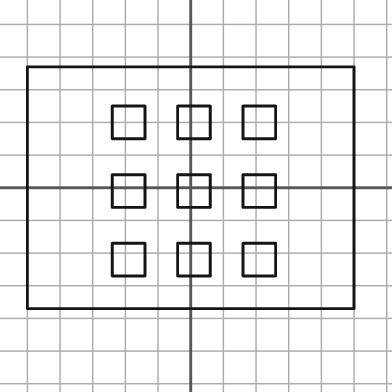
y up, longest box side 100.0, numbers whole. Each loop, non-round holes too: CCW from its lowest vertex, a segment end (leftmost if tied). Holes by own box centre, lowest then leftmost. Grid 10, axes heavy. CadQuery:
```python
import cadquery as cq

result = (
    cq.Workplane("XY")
    .moveTo(-50.0, -37.0)
    .lineTo(50.0, -37.0)
    .lineTo(50.0, 37.0)
    .lineTo(-50.0, 37.0)
    .close()
    .moveTo(-24.0, -27.0)
    .lineTo(-14.0, -27.0)
    .lineTo(-14.0, -17.0)
    .lineTo(-24.0, -17.0)
    .close()
    .moveTo(-4.0, -27.0)
    .lineTo(6.0, -27.0)
    .lineTo(6.0, -17.0)
    .lineTo(-4.0, -17.0)
    .close()
    .moveTo(16.0, -27.0)
    .lineTo(26.0, -27.0)
    .lineTo(26.0, -17.0)
    .lineTo(16.0, -17.0)
    .close()
    .moveTo(-24.0, -6.0)
    .lineTo(-14.0, -6.0)
    .lineTo(-14.0, 4.0)
    .lineTo(-24.0, 4.0)
    .close()
    .moveTo(-4.0, -6.0)
    .lineTo(6.0, -6.0)
    .lineTo(6.0, 4.0)
    .lineTo(-4.0, 4.0)
    .close()
    .moveTo(16.0, -6.0)
    .lineTo(26.0, -6.0)
    .lineTo(26.0, 4.0)
    .lineTo(16.0, 4.0)
    .close()
    .moveTo(-24.0, 15.0)
    .lineTo(-14.0, 15.0)
    .lineTo(-14.0, 25.0)
    .lineTo(-24.0, 25.0)
    .close()
    .moveTo(-4.0, 15.0)
    .lineTo(6.0, 15.0)
    .lineTo(6.0, 25.0)
    .lineTo(-4.0, 25.0)
    .close()
    .moveTo(16.0, 15.0)
    .lineTo(26.0, 15.0)
    .lineTo(26.0, 25.0)
    .lineTo(16.0, 25.0)
    .close()
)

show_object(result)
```